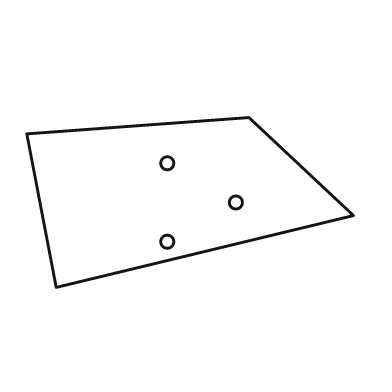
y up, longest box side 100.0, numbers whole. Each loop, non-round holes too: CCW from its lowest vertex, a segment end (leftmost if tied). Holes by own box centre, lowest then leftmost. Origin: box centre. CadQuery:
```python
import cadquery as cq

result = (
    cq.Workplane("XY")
    .moveTo(-41.0, -26.0)
    .lineTo(50.0, -4.0)
    .lineTo(18.0, 26.0)
    .lineTo(-50.0, 21.0)
    .close()
    .moveTo(-7.0, -12.0)
    .circle(2.0)
    .moveTo(14.0, 0.0)
    .circle(2.0)
    .moveTo(-7.0, 12.0)
    .circle(2.0)
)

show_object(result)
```